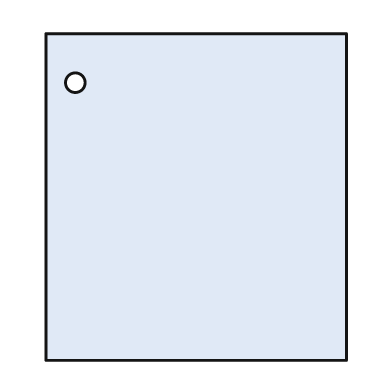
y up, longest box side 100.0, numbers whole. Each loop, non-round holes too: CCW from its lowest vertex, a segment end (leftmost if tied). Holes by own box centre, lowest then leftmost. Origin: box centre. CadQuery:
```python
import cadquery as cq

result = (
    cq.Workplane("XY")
    .moveTo(-46.0, -50.0)
    .lineTo(46.0, -50.0)
    .lineTo(46.0, 50.0)
    .lineTo(-46.0, 50.0)
    .close()
    .moveTo(-37.0, 35.0)
    .circle(3.0)
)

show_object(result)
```